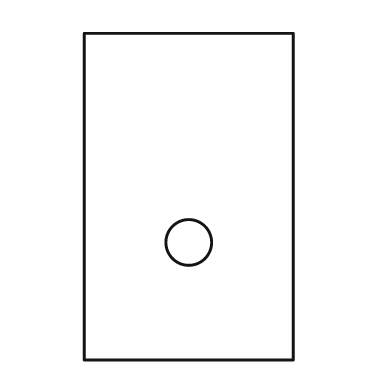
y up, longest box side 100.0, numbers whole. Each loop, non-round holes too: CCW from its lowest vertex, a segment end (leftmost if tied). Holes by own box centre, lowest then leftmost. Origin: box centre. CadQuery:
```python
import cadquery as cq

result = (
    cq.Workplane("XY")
    .moveTo(-32.0, -50.0)
    .lineTo(32.0, -50.0)
    .lineTo(32.0, 50.0)
    .lineTo(-32.0, 50.0)
    .close()
    .moveTo(0.0, -14.0)
    .circle(7.0)
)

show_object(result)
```